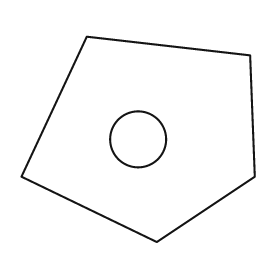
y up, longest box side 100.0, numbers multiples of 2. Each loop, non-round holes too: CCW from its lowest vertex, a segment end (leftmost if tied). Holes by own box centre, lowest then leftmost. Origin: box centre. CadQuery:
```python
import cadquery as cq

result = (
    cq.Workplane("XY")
    .moveTo(8.0, -44.0)
    .lineTo(50.0, -16.0)
    .lineTo(48.0, 36.0)
    .lineTo(-22.0, 44.0)
    .lineTo(-50.0, -16.0)
    .close()
    .moveTo(0.0, 0.0)
    .circle(12.0)
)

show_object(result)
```